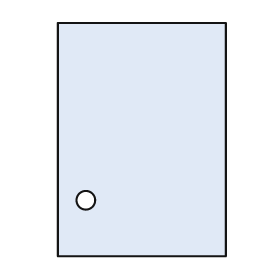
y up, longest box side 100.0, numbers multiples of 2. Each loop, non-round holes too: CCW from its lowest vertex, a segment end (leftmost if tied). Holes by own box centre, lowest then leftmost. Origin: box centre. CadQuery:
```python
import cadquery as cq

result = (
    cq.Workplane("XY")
    .moveTo(-36.0, -50.0)
    .lineTo(36.0, -50.0)
    .lineTo(36.0, 50.0)
    .lineTo(-36.0, 50.0)
    .close()
    .moveTo(-24.0, -26.0)
    .circle(4.0)
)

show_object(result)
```